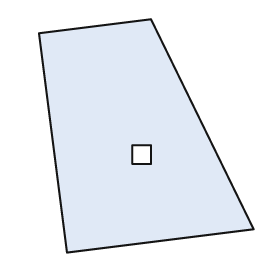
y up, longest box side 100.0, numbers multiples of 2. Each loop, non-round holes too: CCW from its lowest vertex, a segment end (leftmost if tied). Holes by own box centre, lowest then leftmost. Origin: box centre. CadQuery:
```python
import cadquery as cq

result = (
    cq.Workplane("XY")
    .moveTo(-34.0, -50.0)
    .lineTo(46.0, -40.0)
    .lineTo(2.0, 50.0)
    .lineTo(-46.0, 44.0)
    .close()
    .moveTo(-6.0, -12.0)
    .lineTo(2.0, -12.0)
    .lineTo(2.0, -4.0)
    .lineTo(-6.0, -4.0)
    .close()
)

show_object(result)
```